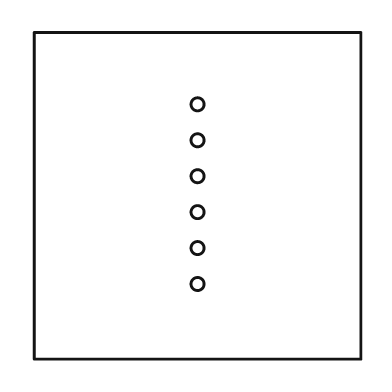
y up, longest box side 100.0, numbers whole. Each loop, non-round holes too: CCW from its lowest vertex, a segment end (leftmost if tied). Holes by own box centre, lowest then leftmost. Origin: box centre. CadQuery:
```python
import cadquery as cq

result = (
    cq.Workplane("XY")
    .moveTo(-50.0, -50.0)
    .lineTo(50.0, -50.0)
    .lineTo(50.0, 50.0)
    .lineTo(-50.0, 50.0)
    .close()
    .moveTo(0.0, -27.0)
    .circle(2.0)
    .moveTo(0.0, -16.0)
    .circle(2.0)
    .moveTo(0.0, -5.0)
    .circle(2.0)
    .moveTo(0.0, 6.0)
    .circle(2.0)
    .moveTo(0.0, 17.0)
    .circle(2.0)
    .moveTo(0.0, 28.0)
    .circle(2.0)
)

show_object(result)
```